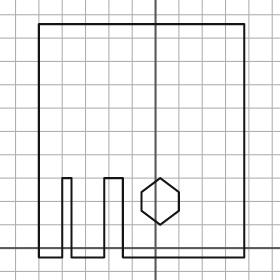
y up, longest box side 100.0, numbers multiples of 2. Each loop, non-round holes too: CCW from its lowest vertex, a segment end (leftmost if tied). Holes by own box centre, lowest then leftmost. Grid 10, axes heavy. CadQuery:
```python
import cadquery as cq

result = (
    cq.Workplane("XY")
    .moveTo(-50.0, -4.0)
    .lineTo(-40.0, -4.0)
    .lineTo(-40.0, 30.0)
    .lineTo(-36.0, 30.0)
    .lineTo(-36.0, -4.0)
    .lineTo(-22.0, -4.0)
    .lineTo(-22.0, 30.0)
    .lineTo(-14.0, 30.0)
    .lineTo(-14.0, -4.0)
    .lineTo(38.0, -4.0)
    .lineTo(38.0, 96.0)
    .lineTo(-50.0, 96.0)
    .close()
    .moveTo(2.0, 10.0)
    .lineTo(10.0, 16.0)
    .lineTo(10.0, 24.0)
    .lineTo(2.0, 30.0)
    .lineTo(-6.0, 24.0)
    .lineTo(-6.0, 16.0)
    .close()
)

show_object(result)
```